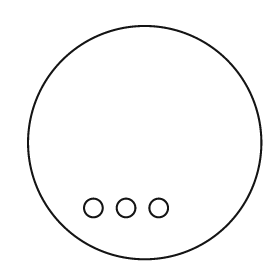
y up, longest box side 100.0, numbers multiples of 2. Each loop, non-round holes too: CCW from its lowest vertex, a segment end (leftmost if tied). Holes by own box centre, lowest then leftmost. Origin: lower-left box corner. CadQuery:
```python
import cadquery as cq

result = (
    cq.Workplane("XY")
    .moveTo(50.0, 50.0)
    .circle(50.0)
    .moveTo(28.0, 22.0)
    .circle(4.0)
    .moveTo(42.0, 22.0)
    .circle(4.0)
    .moveTo(56.0, 22.0)
    .circle(4.0)
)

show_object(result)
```